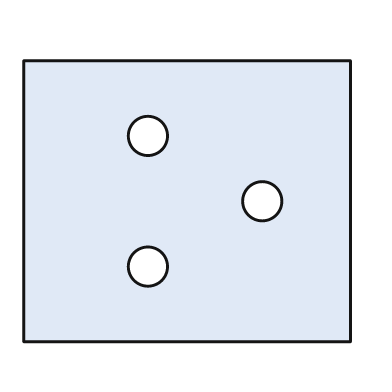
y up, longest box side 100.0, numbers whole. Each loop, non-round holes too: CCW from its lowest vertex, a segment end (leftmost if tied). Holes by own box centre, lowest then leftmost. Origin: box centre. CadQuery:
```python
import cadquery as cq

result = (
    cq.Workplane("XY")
    .moveTo(-50.0, -43.0)
    .lineTo(50.0, -43.0)
    .lineTo(50.0, 43.0)
    .lineTo(-50.0, 43.0)
    .close()
    .moveTo(-12.0, -20.0)
    .circle(6.0)
    .moveTo(23.0, 0.0)
    .circle(6.0)
    .moveTo(-12.0, 20.0)
    .circle(6.0)
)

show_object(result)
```